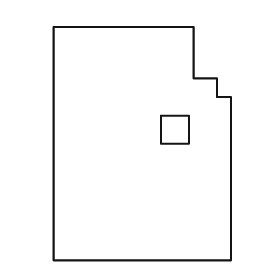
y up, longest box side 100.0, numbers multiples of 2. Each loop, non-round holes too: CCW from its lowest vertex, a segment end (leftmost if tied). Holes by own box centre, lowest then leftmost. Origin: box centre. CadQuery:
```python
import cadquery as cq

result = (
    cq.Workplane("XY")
    .moveTo(-38.0, -50.0)
    .lineTo(38.0, -50.0)
    .lineTo(38.0, 20.0)
    .lineTo(32.0, 20.0)
    .lineTo(32.0, 28.0)
    .lineTo(22.0, 28.0)
    .lineTo(22.0, 50.0)
    .lineTo(-38.0, 50.0)
    .close()
    .moveTo(8.0, 0.0)
    .lineTo(20.0, 0.0)
    .lineTo(20.0, 12.0)
    .lineTo(8.0, 12.0)
    .close()
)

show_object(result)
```